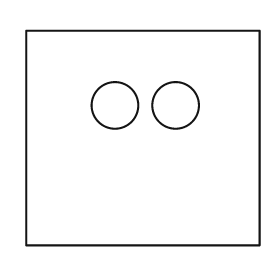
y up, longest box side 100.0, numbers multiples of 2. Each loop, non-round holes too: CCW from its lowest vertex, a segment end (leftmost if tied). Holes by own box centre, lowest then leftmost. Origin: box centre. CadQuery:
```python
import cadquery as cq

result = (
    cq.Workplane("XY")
    .moveTo(-50.0, -46.0)
    .lineTo(50.0, -46.0)
    .lineTo(50.0, 46.0)
    .lineTo(-50.0, 46.0)
    .close()
    .moveTo(-12.0, 14.0)
    .circle(10.0)
    .moveTo(14.0, 14.0)
    .circle(10.0)
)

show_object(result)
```